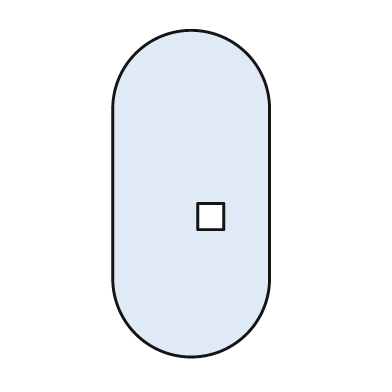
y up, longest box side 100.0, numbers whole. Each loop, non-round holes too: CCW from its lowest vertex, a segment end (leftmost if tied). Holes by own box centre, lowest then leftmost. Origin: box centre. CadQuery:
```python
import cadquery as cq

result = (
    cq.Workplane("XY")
    .moveTo(-24.0, -26.0)
    .threePointArc((0.0, -50.0), (24.0, -26.0))
    .lineTo(24.0, 26.0)
    .threePointArc((0.0, 50.0), (-24.0, 26.0))
    .close()
    .moveTo(2.0, -11.0)
    .lineTo(10.0, -11.0)
    .lineTo(10.0, -3.0)
    .lineTo(2.0, -3.0)
    .close()
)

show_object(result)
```